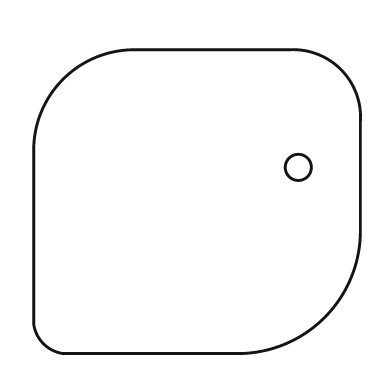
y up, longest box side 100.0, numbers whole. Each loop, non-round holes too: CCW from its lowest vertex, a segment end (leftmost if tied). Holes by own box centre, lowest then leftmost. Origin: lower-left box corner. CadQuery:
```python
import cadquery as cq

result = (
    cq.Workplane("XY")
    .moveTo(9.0, 0.0)
    .lineTo(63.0, 0.0)
    .threePointArc((89.0, 11.0), (100.0, 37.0))
    .lineTo(100.0, 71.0)
    .threePointArc((94.0, 87.0), (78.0, 93.0))
    .lineTo(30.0, 93.0)
    .threePointArc((9.0, 84.0), (0.0, 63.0))
    .lineTo(0.0, 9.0)
    .threePointArc((3.0, 3.0), (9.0, 0.0))
    .close()
    .moveTo(81.0, 57.0)
    .circle(4.0)
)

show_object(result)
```